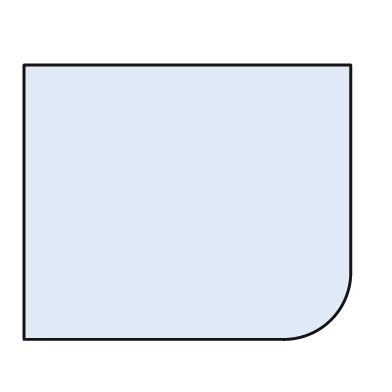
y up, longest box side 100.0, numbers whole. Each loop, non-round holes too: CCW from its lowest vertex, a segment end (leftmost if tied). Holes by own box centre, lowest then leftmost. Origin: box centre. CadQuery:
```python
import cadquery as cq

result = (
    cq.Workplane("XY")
    .moveTo(-50.0, -42.0)
    .lineTo(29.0, -42.0)
    .threePointArc((44.0, -36.0), (50.0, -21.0))
    .lineTo(50.0, 42.0)
    .lineTo(-50.0, 42.0)
    .close()
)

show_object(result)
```